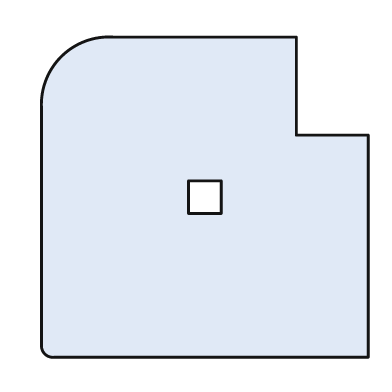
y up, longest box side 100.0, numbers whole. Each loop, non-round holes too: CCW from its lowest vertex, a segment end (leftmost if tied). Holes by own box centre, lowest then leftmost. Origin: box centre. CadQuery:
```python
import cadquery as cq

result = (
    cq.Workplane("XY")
    .moveTo(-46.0, -49.0)
    .lineTo(50.0, -49.0)
    .lineTo(50.0, 19.0)
    .lineTo(28.0, 19.0)
    .lineTo(28.0, 49.0)
    .lineTo(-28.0, 49.0)
    .threePointArc((-44.0, 43.0), (-50.0, 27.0))
    .lineTo(-50.0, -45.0)
    .threePointArc((-49.0, -48.0), (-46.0, -49.0))
    .close()
    .moveTo(-5.0, -5.0)
    .lineTo(5.0, -5.0)
    .lineTo(5.0, 5.0)
    .lineTo(-5.0, 5.0)
    .close()
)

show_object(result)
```